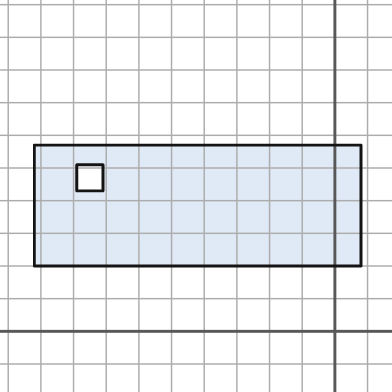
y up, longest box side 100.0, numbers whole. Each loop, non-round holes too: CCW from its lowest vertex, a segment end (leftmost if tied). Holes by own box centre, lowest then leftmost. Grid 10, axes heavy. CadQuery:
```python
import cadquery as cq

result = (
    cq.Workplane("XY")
    .moveTo(-92.0, 20.0)
    .lineTo(8.0, 20.0)
    .lineTo(8.0, 57.0)
    .lineTo(-92.0, 57.0)
    .close()
    .moveTo(-79.0, 43.0)
    .lineTo(-71.0, 43.0)
    .lineTo(-71.0, 51.0)
    .lineTo(-79.0, 51.0)
    .close()
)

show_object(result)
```